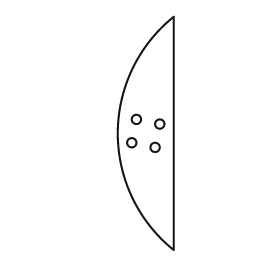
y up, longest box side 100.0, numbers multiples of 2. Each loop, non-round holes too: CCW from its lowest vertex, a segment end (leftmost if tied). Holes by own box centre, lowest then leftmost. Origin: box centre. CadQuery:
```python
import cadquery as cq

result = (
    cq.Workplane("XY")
    .moveTo(12.0, -50.0)
    .lineTo(12.0, 50.0)
    .threePointArc((-12.0, 0.0), (12.0, -50.0))
    .close()
    .moveTo(4.0, -6.0)
    .circle(2.0)
    .moveTo(-6.0, -4.0)
    .circle(2.0)
    .moveTo(6.0, 4.0)
    .circle(2.0)
    .moveTo(-4.0, 6.0)
    .circle(2.0)
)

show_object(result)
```